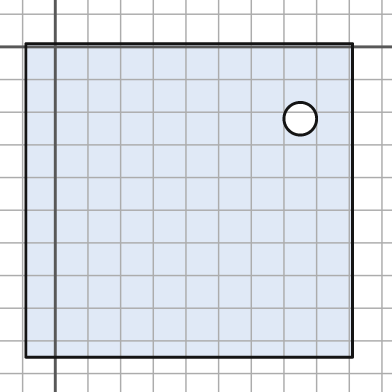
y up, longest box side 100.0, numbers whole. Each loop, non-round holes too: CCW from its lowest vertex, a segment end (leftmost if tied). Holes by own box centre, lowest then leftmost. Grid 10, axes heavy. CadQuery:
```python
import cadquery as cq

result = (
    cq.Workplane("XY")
    .moveTo(-9.0, -95.0)
    .lineTo(91.0, -95.0)
    .lineTo(91.0, 1.0)
    .lineTo(-9.0, 1.0)
    .close()
    .moveTo(75.0, -22.0)
    .circle(5.0)
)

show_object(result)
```